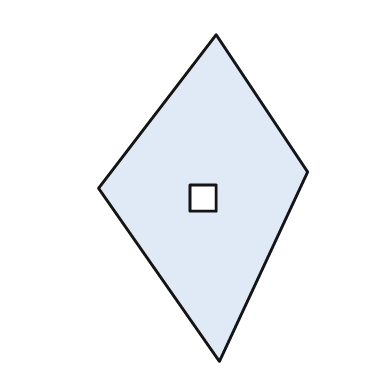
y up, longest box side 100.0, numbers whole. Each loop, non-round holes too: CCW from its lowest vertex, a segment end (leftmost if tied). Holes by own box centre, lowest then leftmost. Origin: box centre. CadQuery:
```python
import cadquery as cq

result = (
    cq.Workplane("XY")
    .moveTo(5.0, -50.0)
    .lineTo(32.0, 8.0)
    .lineTo(4.0, 50.0)
    .lineTo(-32.0, 3.0)
    .close()
    .moveTo(-4.0, -4.0)
    .lineTo(4.0, -4.0)
    .lineTo(4.0, 4.0)
    .lineTo(-4.0, 4.0)
    .close()
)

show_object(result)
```